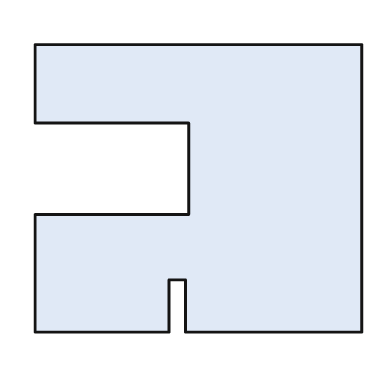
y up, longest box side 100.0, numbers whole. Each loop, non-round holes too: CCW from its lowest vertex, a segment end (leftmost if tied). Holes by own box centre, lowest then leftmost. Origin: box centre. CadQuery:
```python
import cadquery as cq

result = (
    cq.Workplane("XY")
    .moveTo(-50.0, -44.0)
    .lineTo(-9.0, -44.0)
    .lineTo(-9.0, -28.0)
    .lineTo(-4.0, -28.0)
    .lineTo(-4.0, -44.0)
    .lineTo(50.0, -44.0)
    .lineTo(50.0, 44.0)
    .lineTo(-50.0, 44.0)
    .lineTo(-50.0, 20.0)
    .lineTo(-3.0, 20.0)
    .lineTo(-3.0, -8.0)
    .lineTo(-50.0, -8.0)
    .close()
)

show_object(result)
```